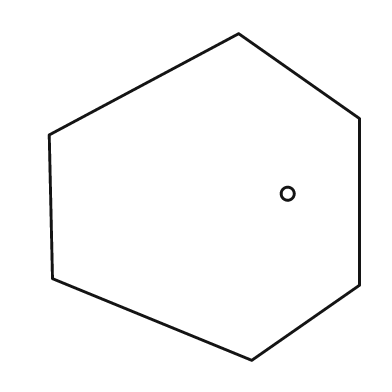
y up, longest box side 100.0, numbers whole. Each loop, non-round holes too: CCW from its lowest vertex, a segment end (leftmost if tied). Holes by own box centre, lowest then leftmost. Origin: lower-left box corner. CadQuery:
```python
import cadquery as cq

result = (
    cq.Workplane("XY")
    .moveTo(62.0, 0.0)
    .lineTo(95.0, 23.0)
    .lineTo(95.0, 74.0)
    .lineTo(58.0, 100.0)
    .lineTo(0.0, 69.0)
    .lineTo(1.0, 25.0)
    .close()
    .moveTo(73.0, 51.0)
    .circle(2.0)
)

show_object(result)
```